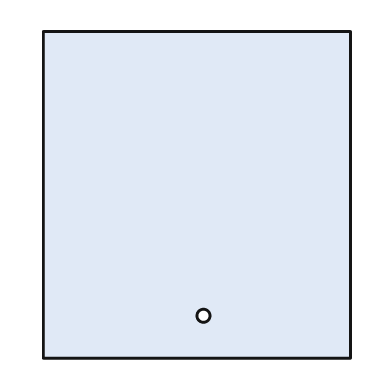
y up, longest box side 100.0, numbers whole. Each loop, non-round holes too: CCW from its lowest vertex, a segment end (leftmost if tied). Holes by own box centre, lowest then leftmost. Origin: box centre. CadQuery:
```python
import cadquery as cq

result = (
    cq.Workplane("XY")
    .moveTo(-47.0, -50.0)
    .lineTo(47.0, -50.0)
    .lineTo(47.0, 50.0)
    .lineTo(-47.0, 50.0)
    .close()
    .moveTo(2.0, -37.0)
    .circle(2.0)
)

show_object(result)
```